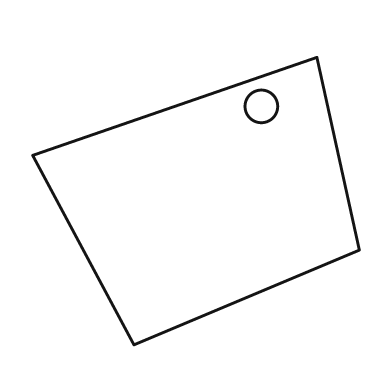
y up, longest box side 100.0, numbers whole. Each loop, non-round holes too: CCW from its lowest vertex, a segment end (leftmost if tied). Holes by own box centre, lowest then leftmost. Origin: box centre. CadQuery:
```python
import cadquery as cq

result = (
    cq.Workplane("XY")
    .moveTo(-19.0, -44.0)
    .lineTo(50.0, -15.0)
    .lineTo(37.0, 44.0)
    .lineTo(-50.0, 14.0)
    .close()
    .moveTo(20.0, 29.0)
    .circle(5.0)
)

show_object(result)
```